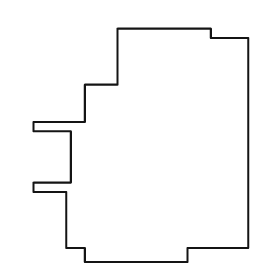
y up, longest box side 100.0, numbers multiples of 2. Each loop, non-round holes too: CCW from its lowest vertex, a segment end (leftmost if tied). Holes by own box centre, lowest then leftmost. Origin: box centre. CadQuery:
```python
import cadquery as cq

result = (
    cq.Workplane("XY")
    .moveTo(-24.0, -50.0)
    .lineTo(20.0, -50.0)
    .lineTo(20.0, -44.0)
    .lineTo(46.0, -44.0)
    .lineTo(46.0, 46.0)
    .lineTo(30.0, 46.0)
    .lineTo(30.0, 50.0)
    .lineTo(-10.0, 50.0)
    .lineTo(-10.0, 26.0)
    .lineTo(-24.0, 26.0)
    .lineTo(-24.0, 10.0)
    .lineTo(-46.0, 10.0)
    .lineTo(-46.0, 6.0)
    .lineTo(-30.0, 6.0)
    .lineTo(-30.0, -16.0)
    .lineTo(-46.0, -16.0)
    .lineTo(-46.0, -20.0)
    .lineTo(-32.0, -20.0)
    .lineTo(-32.0, -44.0)
    .lineTo(-24.0, -44.0)
    .close()
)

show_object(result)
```